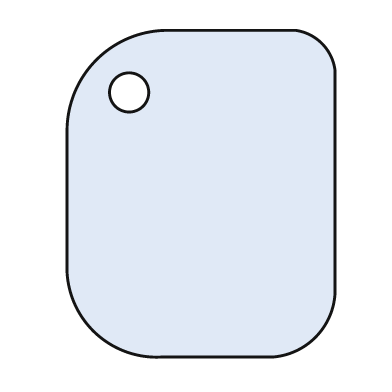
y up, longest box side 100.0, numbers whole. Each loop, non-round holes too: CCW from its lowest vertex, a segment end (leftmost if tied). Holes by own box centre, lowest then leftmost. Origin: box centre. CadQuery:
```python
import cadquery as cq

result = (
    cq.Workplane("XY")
    .moveTo(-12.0, -50.0)
    .lineTo(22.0, -50.0)
    .threePointArc((35.0, -44.0), (41.0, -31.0))
    .lineTo(41.0, 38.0)
    .threePointArc((37.0, 46.0), (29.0, 50.0))
    .lineTo(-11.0, 50.0)
    .threePointArc((-32.0, 41.0), (-41.0, 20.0))
    .lineTo(-41.0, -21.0)
    .threePointArc((-33.0, -42.0), (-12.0, -50.0))
    .close()
    .moveTo(-22.0, 31.0)
    .circle(6.0)
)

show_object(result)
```